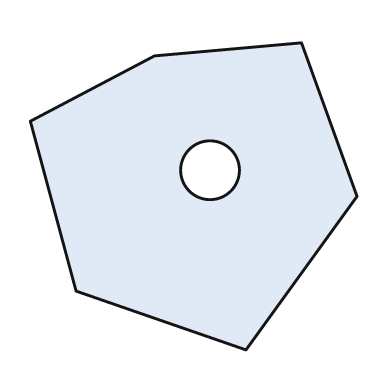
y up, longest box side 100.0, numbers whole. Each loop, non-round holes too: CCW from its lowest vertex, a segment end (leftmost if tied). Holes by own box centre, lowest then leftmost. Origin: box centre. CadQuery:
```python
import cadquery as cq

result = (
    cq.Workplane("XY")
    .moveTo(16.0, -47.0)
    .lineTo(50.0, 0.0)
    .lineTo(33.0, 47.0)
    .lineTo(-12.0, 43.0)
    .lineTo(-50.0, 23.0)
    .lineTo(-36.0, -29.0)
    .close()
    .moveTo(5.0, 8.0)
    .circle(9.0)
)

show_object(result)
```